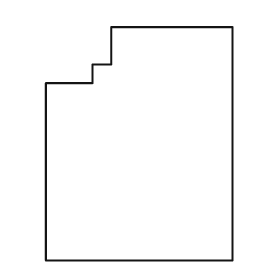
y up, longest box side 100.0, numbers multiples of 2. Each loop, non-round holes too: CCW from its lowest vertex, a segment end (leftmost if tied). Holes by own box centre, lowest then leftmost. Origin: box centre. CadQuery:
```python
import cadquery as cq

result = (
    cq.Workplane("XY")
    .moveTo(-40.0, -50.0)
    .lineTo(40.0, -50.0)
    .lineTo(40.0, 50.0)
    .lineTo(-12.0, 50.0)
    .lineTo(-12.0, 34.0)
    .lineTo(-20.0, 34.0)
    .lineTo(-20.0, 26.0)
    .lineTo(-40.0, 26.0)
    .close()
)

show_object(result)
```